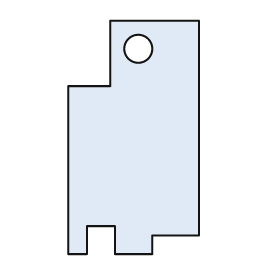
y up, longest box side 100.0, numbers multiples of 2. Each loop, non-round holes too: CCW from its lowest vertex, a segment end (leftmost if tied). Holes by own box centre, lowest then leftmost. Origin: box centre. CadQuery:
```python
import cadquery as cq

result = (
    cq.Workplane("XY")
    .moveTo(-28.0, -50.0)
    .lineTo(-20.0, -50.0)
    .lineTo(-20.0, -38.0)
    .lineTo(-8.0, -38.0)
    .lineTo(-8.0, -50.0)
    .lineTo(8.0, -50.0)
    .lineTo(8.0, -42.0)
    .lineTo(28.0, -42.0)
    .lineTo(28.0, 50.0)
    .lineTo(-10.0, 50.0)
    .lineTo(-10.0, 22.0)
    .lineTo(-28.0, 22.0)
    .close()
    .moveTo(2.0, 38.0)
    .circle(6.0)
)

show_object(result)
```